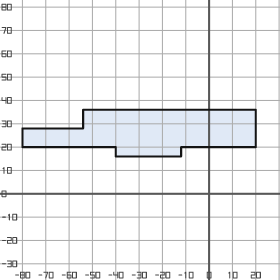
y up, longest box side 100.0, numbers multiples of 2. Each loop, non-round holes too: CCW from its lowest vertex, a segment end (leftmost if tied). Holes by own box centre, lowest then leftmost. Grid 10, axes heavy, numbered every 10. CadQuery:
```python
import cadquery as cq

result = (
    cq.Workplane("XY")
    .moveTo(-40.0, 16.0)
    .lineTo(-12.0, 16.0)
    .lineTo(-12.0, 20.0)
    .lineTo(20.0, 20.0)
    .lineTo(20.0, 36.0)
    .lineTo(-54.0, 36.0)
    .lineTo(-54.0, 28.0)
    .lineTo(-80.0, 28.0)
    .lineTo(-80.0, 20.0)
    .lineTo(-40.0, 20.0)
    .close()
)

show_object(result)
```